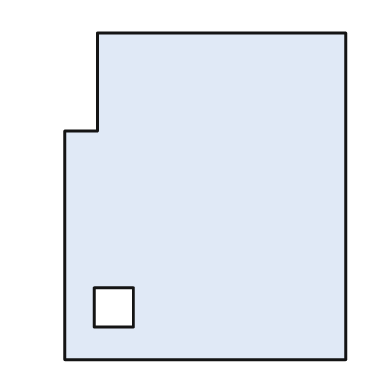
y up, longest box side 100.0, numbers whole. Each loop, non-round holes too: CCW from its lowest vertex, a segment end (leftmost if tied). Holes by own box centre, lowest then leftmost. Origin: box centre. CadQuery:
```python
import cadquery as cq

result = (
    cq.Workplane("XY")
    .moveTo(-43.0, -50.0)
    .lineTo(43.0, -50.0)
    .lineTo(43.0, 50.0)
    .lineTo(-33.0, 50.0)
    .lineTo(-33.0, 20.0)
    .lineTo(-43.0, 20.0)
    .close()
    .moveTo(-34.0, -40.0)
    .lineTo(-22.0, -40.0)
    .lineTo(-22.0, -28.0)
    .lineTo(-34.0, -28.0)
    .close()
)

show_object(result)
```